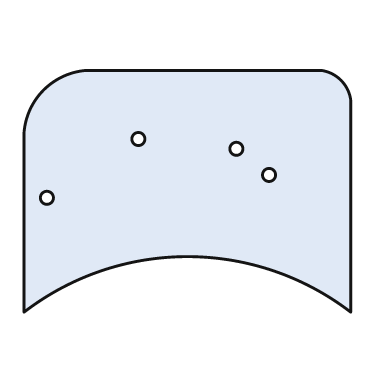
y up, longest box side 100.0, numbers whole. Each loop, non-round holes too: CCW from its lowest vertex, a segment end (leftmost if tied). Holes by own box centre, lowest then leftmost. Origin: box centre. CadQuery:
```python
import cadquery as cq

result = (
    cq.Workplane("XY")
    .moveTo(-50.0, -37.0)
    .threePointArc((0.0, -20.0), (50.0, -37.0))
    .lineTo(50.0, 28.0)
    .threePointArc((47.0, 34.0), (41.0, 37.0))
    .lineTo(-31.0, 37.0)
    .threePointArc((-44.0, 31.0), (-50.0, 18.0))
    .close()
    .moveTo(-43.0, -2.0)
    .circle(2.0)
    .moveTo(25.0, 5.0)
    .circle(2.0)
    .moveTo(15.0, 13.0)
    .circle(2.0)
    .moveTo(-15.0, 16.0)
    .circle(2.0)
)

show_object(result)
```